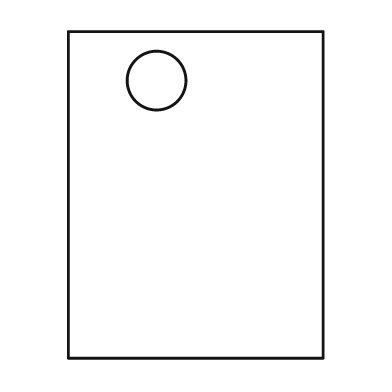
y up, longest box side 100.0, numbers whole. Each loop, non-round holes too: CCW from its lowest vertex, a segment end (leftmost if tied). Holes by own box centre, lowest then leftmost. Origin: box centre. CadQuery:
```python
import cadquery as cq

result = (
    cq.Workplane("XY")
    .moveTo(-39.0, -50.0)
    .lineTo(39.0, -50.0)
    .lineTo(39.0, 50.0)
    .lineTo(-39.0, 50.0)
    .close()
    .moveTo(-12.0, 35.0)
    .circle(9.0)
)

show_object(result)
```